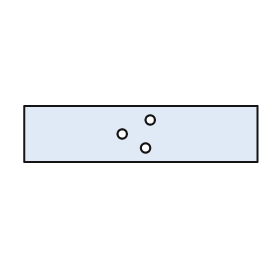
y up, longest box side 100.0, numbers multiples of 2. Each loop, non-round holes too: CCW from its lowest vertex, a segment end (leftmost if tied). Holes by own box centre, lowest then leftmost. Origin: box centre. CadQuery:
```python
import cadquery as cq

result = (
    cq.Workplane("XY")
    .moveTo(-50.0, -12.0)
    .lineTo(50.0, -12.0)
    .lineTo(50.0, 12.0)
    .lineTo(-50.0, 12.0)
    .close()
    .moveTo(2.0, -6.0)
    .circle(2.0)
    .moveTo(-8.0, 0.0)
    .circle(2.0)
    .moveTo(4.0, 6.0)
    .circle(2.0)
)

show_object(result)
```